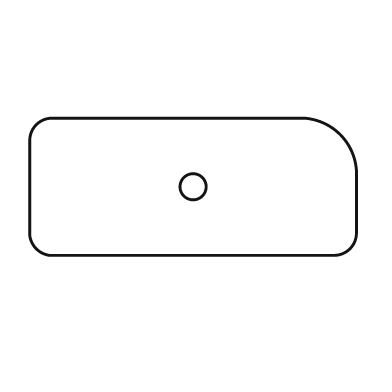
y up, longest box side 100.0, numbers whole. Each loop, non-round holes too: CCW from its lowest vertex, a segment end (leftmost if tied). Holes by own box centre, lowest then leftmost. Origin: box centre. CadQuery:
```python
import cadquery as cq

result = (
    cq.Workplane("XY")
    .moveTo(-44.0, -21.0)
    .lineTo(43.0, -21.0)
    .threePointArc((48.0, -19.0), (50.0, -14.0))
    .lineTo(50.0, 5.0)
    .threePointArc((45.0, 16.0), (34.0, 21.0))
    .lineTo(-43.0, 21.0)
    .threePointArc((-48.0, 19.0), (-50.0, 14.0))
    .lineTo(-50.0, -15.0)
    .threePointArc((-48.0, -19.0), (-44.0, -21.0))
    .close()
    .moveTo(0.0, 0.0)
    .circle(4.0)
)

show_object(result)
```